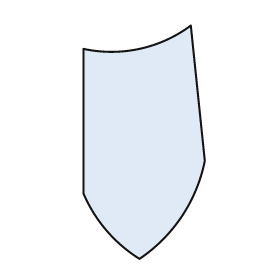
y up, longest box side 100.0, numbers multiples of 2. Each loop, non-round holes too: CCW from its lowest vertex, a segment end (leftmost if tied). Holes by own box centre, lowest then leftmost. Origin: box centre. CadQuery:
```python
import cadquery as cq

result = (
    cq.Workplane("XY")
    .moveTo(-2.0, -50.0)
    .threePointArc((16.0, -32.0), (26.0, -8.0))
    .lineTo(20.0, 50.0)
    .threePointArc((-2.0, 40.0), (-26.0, 40.0))
    .lineTo(-26.0, -22.0)
    .threePointArc((-16.0, -38.0), (-2.0, -50.0))
    .close()
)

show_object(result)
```